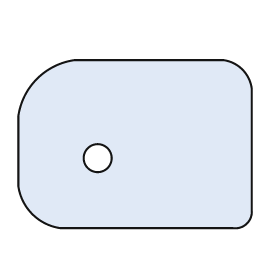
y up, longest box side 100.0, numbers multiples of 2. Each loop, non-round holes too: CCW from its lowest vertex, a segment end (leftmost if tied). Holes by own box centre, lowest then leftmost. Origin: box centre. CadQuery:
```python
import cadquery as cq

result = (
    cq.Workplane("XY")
    .moveTo(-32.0, -36.0)
    .lineTo(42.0, -36.0)
    .threePointArc((48.0, -34.0), (50.0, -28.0))
    .lineTo(50.0, 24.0)
    .threePointArc((46.0, 32.0), (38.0, 36.0))
    .lineTo(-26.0, 36.0)
    .threePointArc((-42.0, 28.0), (-50.0, 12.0))
    .lineTo(-50.0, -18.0)
    .threePointArc((-44.0, -30.0), (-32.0, -36.0))
    .close()
    .moveTo(-16.0, -6.0)
    .circle(6.0)
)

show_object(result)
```